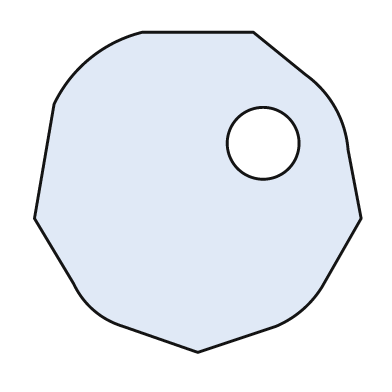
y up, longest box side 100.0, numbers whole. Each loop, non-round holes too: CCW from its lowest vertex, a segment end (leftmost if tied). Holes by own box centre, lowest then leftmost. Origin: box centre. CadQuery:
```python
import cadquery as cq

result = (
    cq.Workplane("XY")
    .moveTo(0.0, -49.0)
    .lineTo(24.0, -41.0)
    .threePointArc((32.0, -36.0), (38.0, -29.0))
    .lineTo(50.0, -8.0)
    .lineTo(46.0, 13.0)
    .threePointArc((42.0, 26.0), (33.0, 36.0))
    .lineTo(17.0, 49.0)
    .lineTo(-17.0, 49.0)
    .threePointArc((-33.0, 41.0), (-44.0, 27.0))
    .lineTo(-50.0, -8.0)
    .lineTo(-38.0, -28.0)
    .threePointArc((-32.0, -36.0), (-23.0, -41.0))
    .close()
    .moveTo(20.0, 15.0)
    .circle(11.0)
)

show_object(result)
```